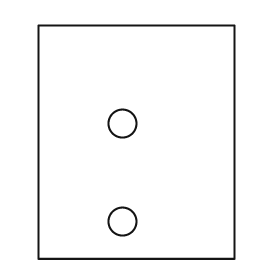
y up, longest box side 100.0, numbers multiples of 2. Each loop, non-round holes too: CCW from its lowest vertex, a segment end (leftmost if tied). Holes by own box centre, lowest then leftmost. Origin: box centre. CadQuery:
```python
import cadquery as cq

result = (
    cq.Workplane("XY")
    .moveTo(-42.0, -50.0)
    .lineTo(42.0, -50.0)
    .lineTo(42.0, 50.0)
    .lineTo(-42.0, 50.0)
    .close()
    .moveTo(-6.0, -34.0)
    .circle(6.0)
    .moveTo(-6.0, 8.0)
    .circle(6.0)
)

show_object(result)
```